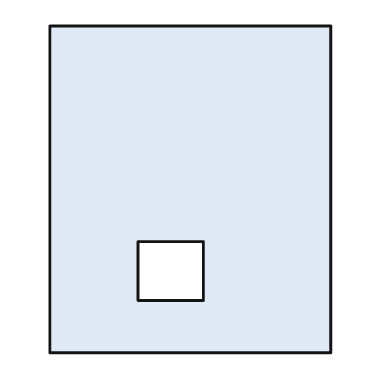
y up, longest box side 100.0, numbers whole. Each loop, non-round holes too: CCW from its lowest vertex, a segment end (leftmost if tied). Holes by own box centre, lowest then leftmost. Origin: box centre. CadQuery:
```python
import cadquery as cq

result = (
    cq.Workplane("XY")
    .moveTo(-43.0, -50.0)
    .lineTo(43.0, -50.0)
    .lineTo(43.0, 50.0)
    .lineTo(-43.0, 50.0)
    .close()
    .moveTo(-16.0, -34.0)
    .lineTo(4.0, -34.0)
    .lineTo(4.0, -16.0)
    .lineTo(-16.0, -16.0)
    .close()
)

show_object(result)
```